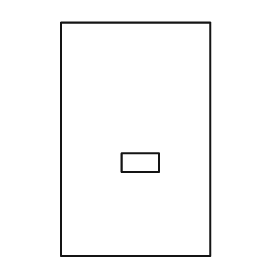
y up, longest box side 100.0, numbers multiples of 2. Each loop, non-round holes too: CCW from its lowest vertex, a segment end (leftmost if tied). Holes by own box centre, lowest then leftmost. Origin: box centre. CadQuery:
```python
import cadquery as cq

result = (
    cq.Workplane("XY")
    .moveTo(-32.0, -50.0)
    .lineTo(32.0, -50.0)
    .lineTo(32.0, 50.0)
    .lineTo(-32.0, 50.0)
    .close()
    .moveTo(-6.0, -14.0)
    .lineTo(10.0, -14.0)
    .lineTo(10.0, -6.0)
    .lineTo(-6.0, -6.0)
    .close()
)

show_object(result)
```